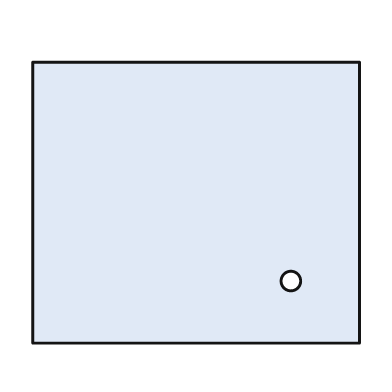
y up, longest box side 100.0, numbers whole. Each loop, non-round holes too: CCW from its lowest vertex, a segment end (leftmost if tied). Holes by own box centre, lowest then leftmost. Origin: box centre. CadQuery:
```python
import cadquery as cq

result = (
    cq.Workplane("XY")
    .moveTo(-50.0, -43.0)
    .lineTo(50.0, -43.0)
    .lineTo(50.0, 43.0)
    .lineTo(-50.0, 43.0)
    .close()
    .moveTo(29.0, -24.0)
    .circle(3.0)
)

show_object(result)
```